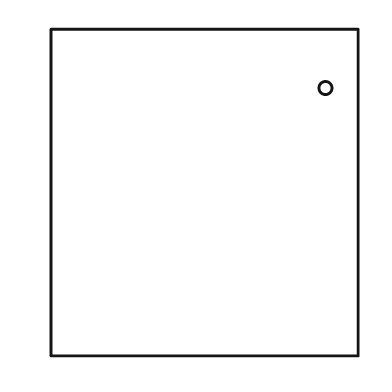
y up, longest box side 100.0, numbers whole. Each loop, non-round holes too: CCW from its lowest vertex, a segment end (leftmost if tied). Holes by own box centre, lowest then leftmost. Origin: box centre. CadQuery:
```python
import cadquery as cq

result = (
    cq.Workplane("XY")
    .moveTo(-47.0, -50.0)
    .lineTo(47.0, -50.0)
    .lineTo(47.0, 50.0)
    .lineTo(-47.0, 50.0)
    .close()
    .moveTo(37.0, 32.0)
    .circle(2.0)
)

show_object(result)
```